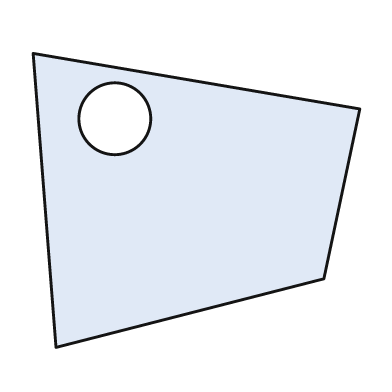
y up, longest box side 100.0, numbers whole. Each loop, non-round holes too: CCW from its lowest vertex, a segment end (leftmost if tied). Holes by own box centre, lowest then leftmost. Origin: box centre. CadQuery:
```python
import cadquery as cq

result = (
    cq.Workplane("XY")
    .moveTo(-43.0, -45.0)
    .lineTo(39.0, -24.0)
    .lineTo(50.0, 28.0)
    .lineTo(-50.0, 45.0)
    .close()
    .moveTo(-25.0, 25.0)
    .circle(11.0)
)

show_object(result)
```